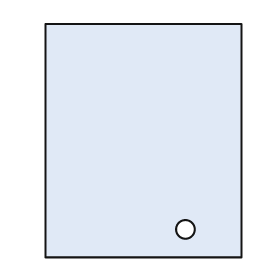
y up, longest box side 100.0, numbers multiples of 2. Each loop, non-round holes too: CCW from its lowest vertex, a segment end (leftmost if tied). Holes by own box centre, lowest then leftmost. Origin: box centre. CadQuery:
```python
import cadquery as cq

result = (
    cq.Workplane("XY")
    .moveTo(-42.0, -50.0)
    .lineTo(42.0, -50.0)
    .lineTo(42.0, 50.0)
    .lineTo(-42.0, 50.0)
    .close()
    .moveTo(18.0, -38.0)
    .circle(4.0)
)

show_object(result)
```